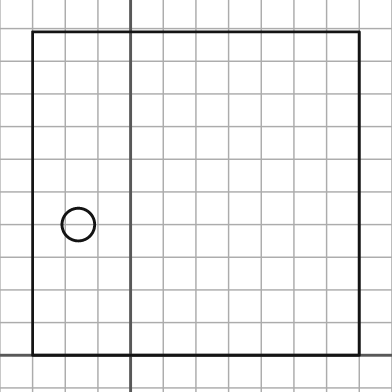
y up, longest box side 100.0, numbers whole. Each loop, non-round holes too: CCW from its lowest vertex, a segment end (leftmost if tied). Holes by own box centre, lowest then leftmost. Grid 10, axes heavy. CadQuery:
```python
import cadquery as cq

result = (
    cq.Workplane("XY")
    .moveTo(-30.0, 0.0)
    .lineTo(70.0, 0.0)
    .lineTo(70.0, 99.0)
    .lineTo(-30.0, 99.0)
    .close()
    .moveTo(-16.0, 40.0)
    .circle(5.0)
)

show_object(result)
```